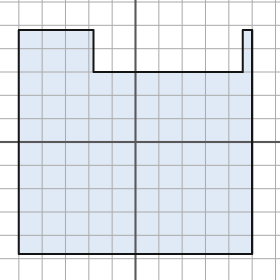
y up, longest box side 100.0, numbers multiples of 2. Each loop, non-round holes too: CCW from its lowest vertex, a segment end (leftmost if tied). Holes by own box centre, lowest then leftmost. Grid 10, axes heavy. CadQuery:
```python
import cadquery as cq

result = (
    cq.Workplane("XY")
    .moveTo(-50.0, -48.0)
    .lineTo(50.0, -48.0)
    .lineTo(50.0, 48.0)
    .lineTo(46.0, 48.0)
    .lineTo(46.0, 30.0)
    .lineTo(-18.0, 30.0)
    .lineTo(-18.0, 48.0)
    .lineTo(-50.0, 48.0)
    .close()
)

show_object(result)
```